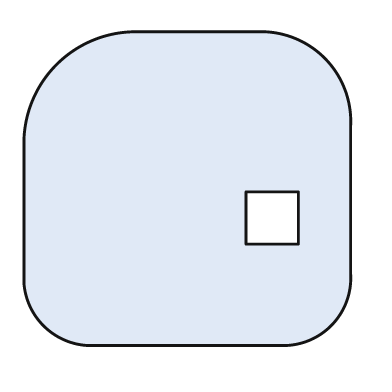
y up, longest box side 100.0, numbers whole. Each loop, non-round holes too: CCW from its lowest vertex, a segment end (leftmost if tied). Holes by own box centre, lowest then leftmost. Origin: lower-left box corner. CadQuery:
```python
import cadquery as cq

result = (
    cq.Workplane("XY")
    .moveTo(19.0, 0.0)
    .lineTo(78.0, 0.0)
    .threePointArc((94.0, 6.0), (100.0, 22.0))
    .lineTo(100.0, 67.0)
    .threePointArc((92.0, 88.0), (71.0, 96.0))
    .lineTo(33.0, 96.0)
    .threePointArc((10.0, 86.0), (0.0, 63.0))
    .lineTo(0.0, 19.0)
    .threePointArc((6.0, 6.0), (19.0, 0.0))
    .close()
    .moveTo(68.0, 31.0)
    .lineTo(84.0, 31.0)
    .lineTo(84.0, 47.0)
    .lineTo(68.0, 47.0)
    .close()
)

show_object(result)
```